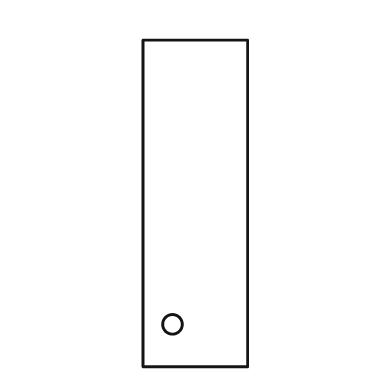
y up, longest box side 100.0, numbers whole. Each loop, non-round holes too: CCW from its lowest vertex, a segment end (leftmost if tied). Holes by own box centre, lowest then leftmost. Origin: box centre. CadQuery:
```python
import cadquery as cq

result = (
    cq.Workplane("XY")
    .moveTo(-16.0, -50.0)
    .lineTo(16.0, -50.0)
    .lineTo(16.0, 50.0)
    .lineTo(-16.0, 50.0)
    .close()
    .moveTo(-7.0, -37.0)
    .circle(3.0)
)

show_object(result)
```